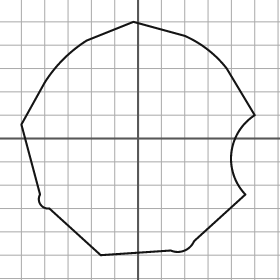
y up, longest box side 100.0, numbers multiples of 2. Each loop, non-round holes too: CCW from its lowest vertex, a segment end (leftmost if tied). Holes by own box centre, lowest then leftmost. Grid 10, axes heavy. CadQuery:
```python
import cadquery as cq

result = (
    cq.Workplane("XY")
    .moveTo(-16.0, -50.0)
    .lineTo(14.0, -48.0)
    .threePointArc((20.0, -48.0), (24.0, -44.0))
    .lineTo(46.0, -24.0)
    .threePointArc((40.0, -6.0), (50.0, 10.0))
    .lineTo(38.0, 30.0)
    .threePointArc((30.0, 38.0), (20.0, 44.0))
    .lineTo(-2.0, 50.0)
    .lineTo(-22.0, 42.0)
    .threePointArc((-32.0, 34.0), (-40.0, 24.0))
    .lineTo(-50.0, 6.0)
    .lineTo(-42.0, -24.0)
    .threePointArc((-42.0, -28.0), (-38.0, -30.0))
    .close()
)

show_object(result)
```